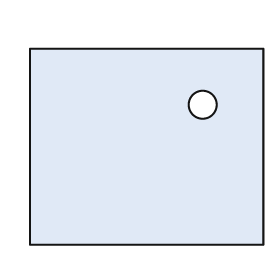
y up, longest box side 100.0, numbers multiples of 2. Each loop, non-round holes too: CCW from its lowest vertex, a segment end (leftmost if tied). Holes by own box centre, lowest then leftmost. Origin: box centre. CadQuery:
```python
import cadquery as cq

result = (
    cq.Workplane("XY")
    .moveTo(-50.0, -42.0)
    .lineTo(50.0, -42.0)
    .lineTo(50.0, 42.0)
    .lineTo(-50.0, 42.0)
    .close()
    .moveTo(24.0, 18.0)
    .circle(6.0)
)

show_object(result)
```